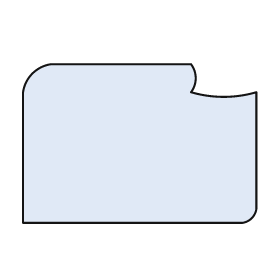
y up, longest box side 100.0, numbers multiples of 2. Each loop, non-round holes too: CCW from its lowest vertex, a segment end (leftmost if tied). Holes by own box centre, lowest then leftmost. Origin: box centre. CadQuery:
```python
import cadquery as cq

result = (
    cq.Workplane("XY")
    .moveTo(-50.0, -34.0)
    .lineTo(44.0, -34.0)
    .threePointArc((48.0, -32.0), (50.0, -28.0))
    .lineTo(50.0, 22.0)
    .threePointArc((36.0, 20.0), (22.0, 22.0))
    .threePointArc((24.0, 28.0), (22.0, 34.0))
    .lineTo(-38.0, 34.0)
    .threePointArc((-46.0, 30.0), (-50.0, 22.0))
    .close()
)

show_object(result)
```